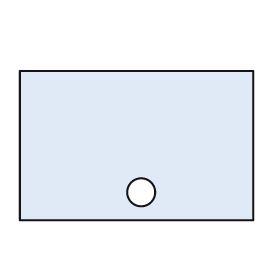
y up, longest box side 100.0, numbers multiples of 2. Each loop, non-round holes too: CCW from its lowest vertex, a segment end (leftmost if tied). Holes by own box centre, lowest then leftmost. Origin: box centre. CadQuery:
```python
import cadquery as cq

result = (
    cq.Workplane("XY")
    .moveTo(-50.0, -32.0)
    .lineTo(50.0, -32.0)
    .lineTo(50.0, 32.0)
    .lineTo(-50.0, 32.0)
    .close()
    .moveTo(2.0, -20.0)
    .circle(6.0)
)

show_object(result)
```